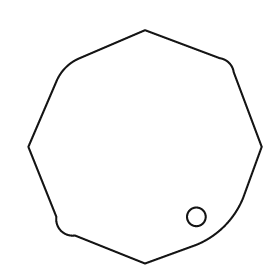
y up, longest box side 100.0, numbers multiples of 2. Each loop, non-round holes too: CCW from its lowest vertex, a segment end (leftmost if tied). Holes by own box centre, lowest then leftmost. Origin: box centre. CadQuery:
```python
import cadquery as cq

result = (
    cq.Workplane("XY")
    .moveTo(0.0, -50.0)
    .lineTo(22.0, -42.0)
    .threePointArc((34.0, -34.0), (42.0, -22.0))
    .lineTo(50.0, 0.0)
    .lineTo(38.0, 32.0)
    .threePointArc((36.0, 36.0), (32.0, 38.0))
    .lineTo(0.0, 50.0)
    .lineTo(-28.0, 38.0)
    .threePointArc((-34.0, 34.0), (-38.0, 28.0))
    .lineTo(-50.0, 0.0)
    .lineTo(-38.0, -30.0)
    .threePointArc((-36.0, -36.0), (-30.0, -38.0))
    .close()
    .moveTo(22.0, -30.0)
    .circle(4.0)
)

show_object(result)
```